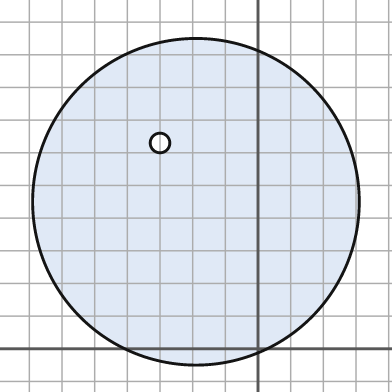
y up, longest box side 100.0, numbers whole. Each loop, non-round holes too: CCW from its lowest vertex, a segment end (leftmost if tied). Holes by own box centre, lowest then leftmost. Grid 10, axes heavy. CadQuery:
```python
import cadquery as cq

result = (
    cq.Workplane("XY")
    .moveTo(-19.0, 45.0)
    .circle(50.0)
    .moveTo(-30.0, 63.0)
    .circle(3.0)
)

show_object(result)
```